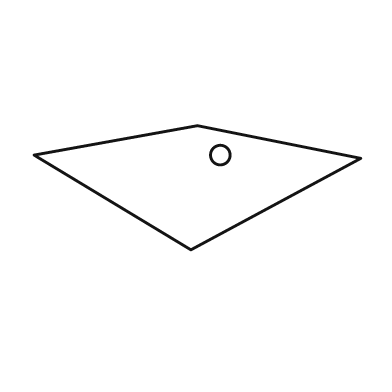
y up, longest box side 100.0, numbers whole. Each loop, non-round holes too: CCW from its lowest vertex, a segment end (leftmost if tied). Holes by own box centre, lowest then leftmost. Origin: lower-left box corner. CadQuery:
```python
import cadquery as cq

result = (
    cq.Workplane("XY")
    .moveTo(48.0, 0.0)
    .lineTo(100.0, 28.0)
    .lineTo(50.0, 38.0)
    .lineTo(0.0, 29.0)
    .close()
    .moveTo(57.0, 29.0)
    .circle(3.0)
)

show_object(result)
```